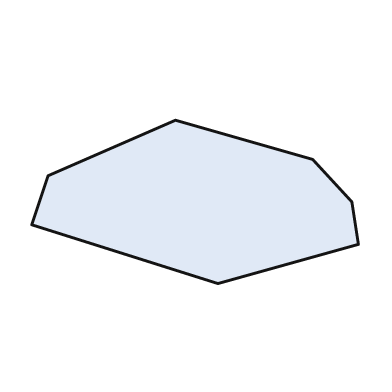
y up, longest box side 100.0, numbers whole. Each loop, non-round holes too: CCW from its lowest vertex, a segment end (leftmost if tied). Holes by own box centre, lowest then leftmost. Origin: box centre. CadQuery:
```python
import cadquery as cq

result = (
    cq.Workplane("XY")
    .moveTo(7.0, -25.0)
    .lineTo(50.0, -13.0)
    .lineTo(48.0, 0.0)
    .lineTo(36.0, 13.0)
    .lineTo(-6.0, 25.0)
    .lineTo(-45.0, 8.0)
    .lineTo(-50.0, -7.0)
    .close()
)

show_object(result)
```